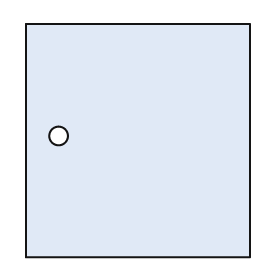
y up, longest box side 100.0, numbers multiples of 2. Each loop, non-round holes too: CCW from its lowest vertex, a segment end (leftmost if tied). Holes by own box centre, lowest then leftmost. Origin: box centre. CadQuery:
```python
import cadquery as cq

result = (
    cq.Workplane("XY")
    .moveTo(-48.0, -50.0)
    .lineTo(48.0, -50.0)
    .lineTo(48.0, 50.0)
    .lineTo(-48.0, 50.0)
    .close()
    .moveTo(-34.0, 2.0)
    .circle(4.0)
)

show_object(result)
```